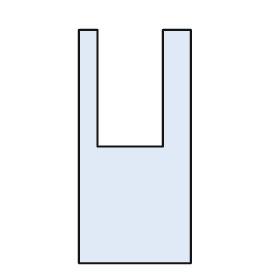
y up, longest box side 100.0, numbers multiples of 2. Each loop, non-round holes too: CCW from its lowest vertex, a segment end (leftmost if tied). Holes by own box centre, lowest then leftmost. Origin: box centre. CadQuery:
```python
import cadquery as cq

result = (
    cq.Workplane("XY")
    .moveTo(-24.0, -50.0)
    .lineTo(24.0, -50.0)
    .lineTo(24.0, 50.0)
    .lineTo(12.0, 50.0)
    .lineTo(12.0, 0.0)
    .lineTo(-16.0, 0.0)
    .lineTo(-16.0, 50.0)
    .lineTo(-24.0, 50.0)
    .close()
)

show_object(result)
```